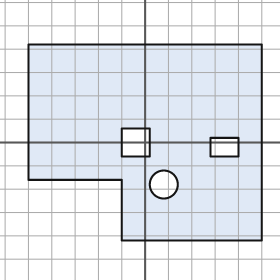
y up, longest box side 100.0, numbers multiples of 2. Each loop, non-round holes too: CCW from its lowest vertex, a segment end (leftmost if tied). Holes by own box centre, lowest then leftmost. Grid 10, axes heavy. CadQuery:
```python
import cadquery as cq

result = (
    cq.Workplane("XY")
    .moveTo(-10.0, -42.0)
    .lineTo(50.0, -42.0)
    .lineTo(50.0, 42.0)
    .lineTo(-50.0, 42.0)
    .lineTo(-50.0, -16.0)
    .lineTo(-10.0, -16.0)
    .close()
    .moveTo(8.0, -18.0)
    .circle(6.0)
    .moveTo(28.0, -6.0)
    .lineTo(40.0, -6.0)
    .lineTo(40.0, 2.0)
    .lineTo(28.0, 2.0)
    .close()
    .moveTo(-10.0, -6.0)
    .lineTo(2.0, -6.0)
    .lineTo(2.0, 6.0)
    .lineTo(-10.0, 6.0)
    .close()
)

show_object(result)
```